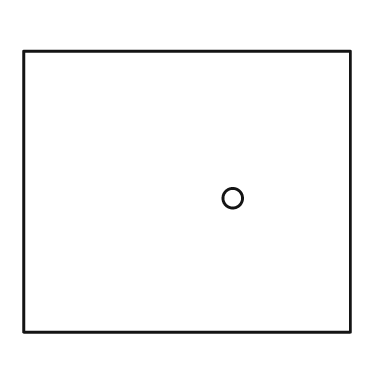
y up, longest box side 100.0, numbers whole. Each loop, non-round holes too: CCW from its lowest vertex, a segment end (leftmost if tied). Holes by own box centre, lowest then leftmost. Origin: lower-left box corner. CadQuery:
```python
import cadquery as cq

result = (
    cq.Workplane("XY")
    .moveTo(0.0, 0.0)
    .lineTo(100.0, 0.0)
    .lineTo(100.0, 86.0)
    .lineTo(0.0, 86.0)
    .close()
    .moveTo(64.0, 41.0)
    .circle(3.0)
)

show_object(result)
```